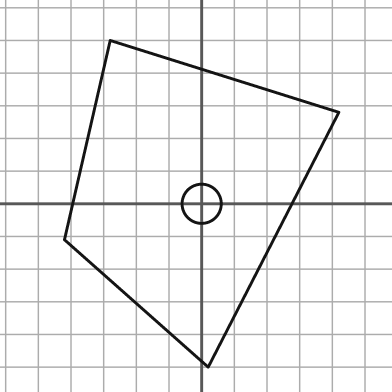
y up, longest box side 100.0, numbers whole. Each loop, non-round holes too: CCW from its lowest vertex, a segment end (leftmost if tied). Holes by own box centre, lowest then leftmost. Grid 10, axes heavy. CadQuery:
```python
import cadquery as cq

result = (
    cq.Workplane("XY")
    .moveTo(2.0, -50.0)
    .lineTo(42.0, 28.0)
    .lineTo(-28.0, 50.0)
    .lineTo(-42.0, -11.0)
    .close()
    .moveTo(0.0, 0.0)
    .circle(6.0)
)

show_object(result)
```